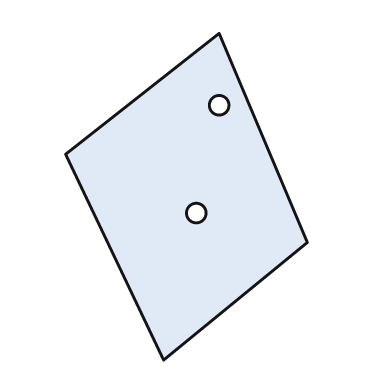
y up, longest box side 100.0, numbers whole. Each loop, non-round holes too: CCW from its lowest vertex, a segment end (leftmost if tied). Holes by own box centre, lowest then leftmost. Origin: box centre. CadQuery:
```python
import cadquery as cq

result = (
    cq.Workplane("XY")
    .moveTo(-7.0, -50.0)
    .lineTo(37.0, -14.0)
    .lineTo(10.0, 50.0)
    .lineTo(-37.0, 13.0)
    .close()
    .moveTo(3.0, -5.0)
    .circle(3.0)
    .moveTo(10.0, 28.0)
    .circle(3.0)
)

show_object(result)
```